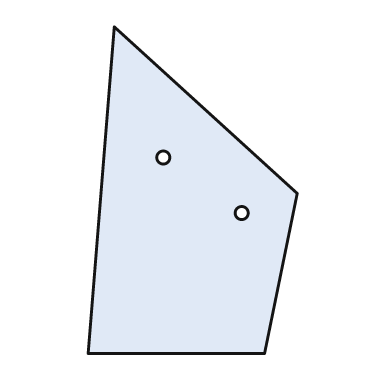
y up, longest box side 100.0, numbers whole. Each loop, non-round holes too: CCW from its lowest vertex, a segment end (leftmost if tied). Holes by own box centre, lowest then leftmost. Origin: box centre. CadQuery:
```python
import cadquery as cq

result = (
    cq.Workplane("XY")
    .moveTo(-32.0, -50.0)
    .lineTo(22.0, -50.0)
    .lineTo(32.0, -1.0)
    .lineTo(-24.0, 50.0)
    .close()
    .moveTo(15.0, -7.0)
    .circle(2.0)
    .moveTo(-9.0, 10.0)
    .circle(2.0)
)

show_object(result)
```